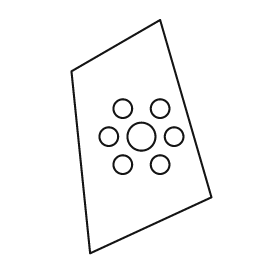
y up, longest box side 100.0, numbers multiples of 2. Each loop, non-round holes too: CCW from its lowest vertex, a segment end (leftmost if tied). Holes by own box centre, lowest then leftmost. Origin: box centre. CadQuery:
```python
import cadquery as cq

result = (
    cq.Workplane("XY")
    .moveTo(-22.0, -50.0)
    .lineTo(30.0, -26.0)
    .lineTo(8.0, 50.0)
    .lineTo(-30.0, 28.0)
    .close()
    .moveTo(-8.0, -12.0)
    .circle(4.0)
    .moveTo(8.0, -12.0)
    .circle(4.0)
    .moveTo(-14.0, 0.0)
    .circle(4.0)
    .moveTo(0.0, 0.0)
    .circle(6.0)
    .moveTo(14.0, 0.0)
    .circle(4.0)
    .moveTo(-8.0, 12.0)
    .circle(4.0)
    .moveTo(8.0, 12.0)
    .circle(4.0)
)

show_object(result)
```